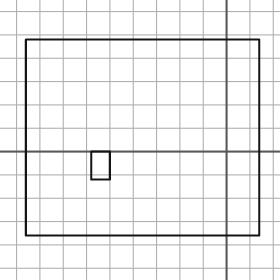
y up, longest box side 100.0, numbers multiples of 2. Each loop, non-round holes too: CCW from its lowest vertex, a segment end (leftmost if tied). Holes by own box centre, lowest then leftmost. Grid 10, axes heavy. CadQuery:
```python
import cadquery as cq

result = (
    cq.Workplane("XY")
    .moveTo(-86.0, -36.0)
    .lineTo(14.0, -36.0)
    .lineTo(14.0, 48.0)
    .lineTo(-86.0, 48.0)
    .close()
    .moveTo(-58.0, -12.0)
    .lineTo(-50.0, -12.0)
    .lineTo(-50.0, 0.0)
    .lineTo(-58.0, 0.0)
    .close()
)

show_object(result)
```